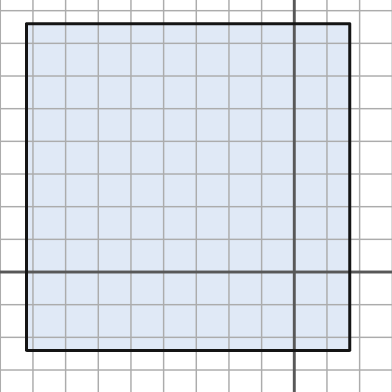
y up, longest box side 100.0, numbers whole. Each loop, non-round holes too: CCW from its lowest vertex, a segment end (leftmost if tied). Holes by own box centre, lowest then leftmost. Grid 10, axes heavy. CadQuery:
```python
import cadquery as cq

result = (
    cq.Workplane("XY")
    .moveTo(-82.0, -24.0)
    .lineTo(17.0, -24.0)
    .lineTo(17.0, 76.0)
    .lineTo(-82.0, 76.0)
    .close()
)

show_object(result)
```